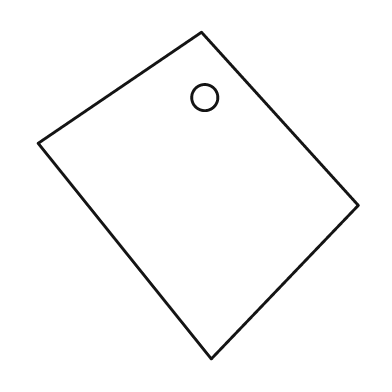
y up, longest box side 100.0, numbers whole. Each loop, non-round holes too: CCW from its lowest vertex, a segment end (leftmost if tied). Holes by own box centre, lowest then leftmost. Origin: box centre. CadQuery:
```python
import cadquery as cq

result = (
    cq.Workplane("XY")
    .moveTo(4.0, -50.0)
    .lineTo(49.0, -3.0)
    .lineTo(1.0, 50.0)
    .lineTo(-49.0, 16.0)
    .close()
    .moveTo(2.0, 30.0)
    .circle(4.0)
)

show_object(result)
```